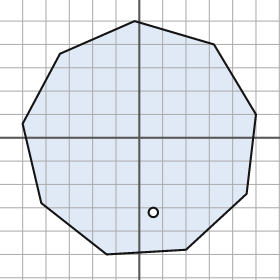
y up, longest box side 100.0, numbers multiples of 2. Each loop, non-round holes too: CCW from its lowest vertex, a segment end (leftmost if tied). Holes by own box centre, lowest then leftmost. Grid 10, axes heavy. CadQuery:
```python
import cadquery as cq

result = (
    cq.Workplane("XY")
    .moveTo(-14.0, -50.0)
    .lineTo(20.0, -48.0)
    .lineTo(46.0, -24.0)
    .lineTo(50.0, 10.0)
    .lineTo(32.0, 40.0)
    .lineTo(-2.0, 50.0)
    .lineTo(-34.0, 36.0)
    .lineTo(-50.0, 6.0)
    .lineTo(-42.0, -28.0)
    .close()
    .moveTo(6.0, -32.0)
    .circle(2.0)
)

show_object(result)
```